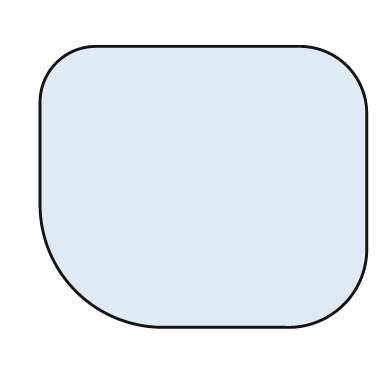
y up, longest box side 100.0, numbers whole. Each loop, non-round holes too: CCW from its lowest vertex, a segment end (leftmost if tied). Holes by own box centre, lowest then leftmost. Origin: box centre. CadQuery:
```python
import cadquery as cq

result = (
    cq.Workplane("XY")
    .moveTo(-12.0, -43.0)
    .lineTo(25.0, -43.0)
    .threePointArc((43.0, -36.0), (50.0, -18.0))
    .lineTo(50.0, 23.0)
    .threePointArc((44.0, 37.0), (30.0, 43.0))
    .lineTo(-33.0, 43.0)
    .threePointArc((-45.0, 38.0), (-50.0, 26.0))
    .lineTo(-50.0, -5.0)
    .threePointArc((-39.0, -32.0), (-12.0, -43.0))
    .close()
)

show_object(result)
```